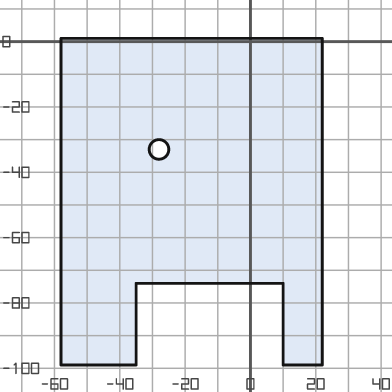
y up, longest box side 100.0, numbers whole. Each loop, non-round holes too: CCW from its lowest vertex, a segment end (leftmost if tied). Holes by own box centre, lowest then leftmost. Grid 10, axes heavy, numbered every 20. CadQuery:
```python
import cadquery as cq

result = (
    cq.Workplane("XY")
    .moveTo(-58.0, -99.0)
    .lineTo(-35.0, -99.0)
    .lineTo(-35.0, -74.0)
    .lineTo(10.0, -74.0)
    .lineTo(10.0, -99.0)
    .lineTo(22.0, -99.0)
    .lineTo(22.0, 1.0)
    .lineTo(-58.0, 1.0)
    .close()
    .moveTo(-28.0, -33.0)
    .circle(3.0)
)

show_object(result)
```